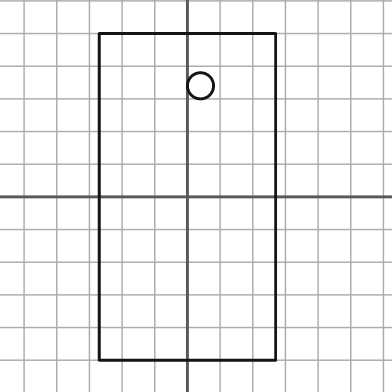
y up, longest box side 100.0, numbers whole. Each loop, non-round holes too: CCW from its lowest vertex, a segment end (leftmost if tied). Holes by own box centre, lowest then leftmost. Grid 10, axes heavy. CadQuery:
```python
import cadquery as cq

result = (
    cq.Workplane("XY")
    .moveTo(-27.0, -50.0)
    .lineTo(27.0, -50.0)
    .lineTo(27.0, 50.0)
    .lineTo(-27.0, 50.0)
    .close()
    .moveTo(4.0, 34.0)
    .circle(4.0)
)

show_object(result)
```